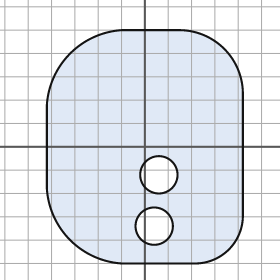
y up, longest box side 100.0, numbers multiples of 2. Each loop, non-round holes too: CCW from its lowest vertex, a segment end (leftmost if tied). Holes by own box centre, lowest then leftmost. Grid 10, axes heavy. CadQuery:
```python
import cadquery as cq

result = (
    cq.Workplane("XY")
    .moveTo(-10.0, -50.0)
    .lineTo(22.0, -50.0)
    .threePointArc((36.0, -44.0), (42.0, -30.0))
    .lineTo(42.0, 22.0)
    .threePointArc((34.0, 42.0), (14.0, 50.0))
    .lineTo(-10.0, 50.0)
    .threePointArc((-32.0, 40.0), (-42.0, 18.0))
    .lineTo(-42.0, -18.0)
    .threePointArc((-32.0, -40.0), (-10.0, -50.0))
    .close()
    .moveTo(4.0, -34.0)
    .circle(8.0)
    .moveTo(6.0, -12.0)
    .circle(8.0)
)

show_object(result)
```